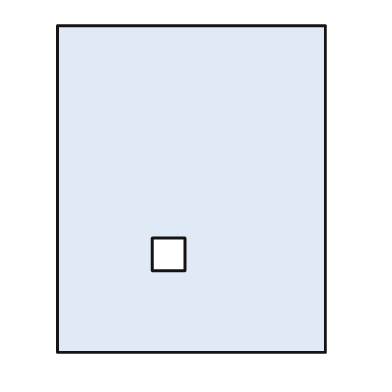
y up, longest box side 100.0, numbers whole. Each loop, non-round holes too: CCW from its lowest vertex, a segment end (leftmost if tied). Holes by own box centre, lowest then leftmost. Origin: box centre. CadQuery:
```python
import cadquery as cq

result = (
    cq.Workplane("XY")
    .moveTo(-41.0, -50.0)
    .lineTo(41.0, -50.0)
    .lineTo(41.0, 50.0)
    .lineTo(-41.0, 50.0)
    .close()
    .moveTo(-12.0, -25.0)
    .lineTo(-2.0, -25.0)
    .lineTo(-2.0, -15.0)
    .lineTo(-12.0, -15.0)
    .close()
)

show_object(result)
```